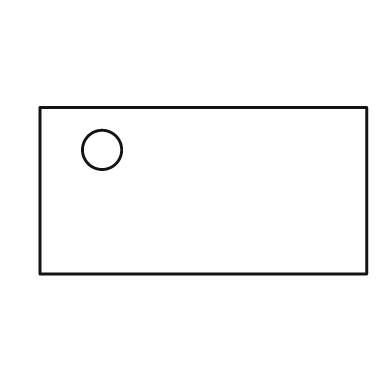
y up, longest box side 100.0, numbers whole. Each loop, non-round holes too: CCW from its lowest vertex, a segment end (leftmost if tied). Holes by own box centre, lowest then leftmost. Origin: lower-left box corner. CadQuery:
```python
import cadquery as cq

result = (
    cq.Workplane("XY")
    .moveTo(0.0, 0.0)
    .lineTo(100.0, 0.0)
    .lineTo(100.0, 51.0)
    .lineTo(0.0, 51.0)
    .close()
    .moveTo(19.0, 38.0)
    .circle(6.0)
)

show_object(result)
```